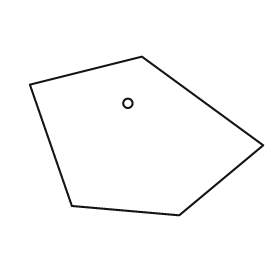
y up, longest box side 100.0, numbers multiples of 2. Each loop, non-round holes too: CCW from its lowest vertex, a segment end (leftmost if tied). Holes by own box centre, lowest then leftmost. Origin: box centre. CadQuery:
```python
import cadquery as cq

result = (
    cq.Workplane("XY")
    .moveTo(14.0, -34.0)
    .lineTo(50.0, -4.0)
    .lineTo(-2.0, 34.0)
    .lineTo(-50.0, 22.0)
    .lineTo(-32.0, -30.0)
    .close()
    .moveTo(-8.0, 14.0)
    .circle(2.0)
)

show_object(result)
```